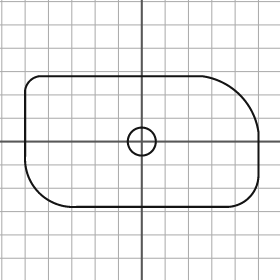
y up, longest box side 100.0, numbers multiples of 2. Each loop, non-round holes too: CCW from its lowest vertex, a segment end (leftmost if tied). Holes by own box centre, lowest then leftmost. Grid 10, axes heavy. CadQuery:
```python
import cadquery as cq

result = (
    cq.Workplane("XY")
    .moveTo(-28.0, -28.0)
    .lineTo(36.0, -28.0)
    .threePointArc((46.0, -24.0), (50.0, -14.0))
    .lineTo(50.0, 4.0)
    .threePointArc((42.0, 20.0), (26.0, 28.0))
    .lineTo(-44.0, 28.0)
    .threePointArc((-48.0, 26.0), (-50.0, 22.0))
    .lineTo(-50.0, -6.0)
    .threePointArc((-44.0, -22.0), (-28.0, -28.0))
    .close()
    .moveTo(0.0, 0.0)
    .circle(6.0)
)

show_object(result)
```